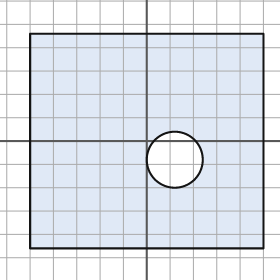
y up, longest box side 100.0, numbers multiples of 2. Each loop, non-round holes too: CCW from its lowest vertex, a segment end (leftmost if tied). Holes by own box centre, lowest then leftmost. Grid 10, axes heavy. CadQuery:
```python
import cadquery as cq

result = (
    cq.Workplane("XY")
    .moveTo(-50.0, -46.0)
    .lineTo(50.0, -46.0)
    .lineTo(50.0, 46.0)
    .lineTo(-50.0, 46.0)
    .close()
    .moveTo(12.0, -8.0)
    .circle(12.0)
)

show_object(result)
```